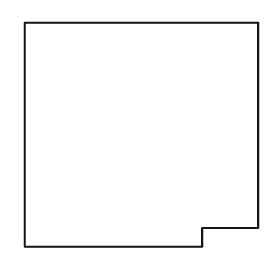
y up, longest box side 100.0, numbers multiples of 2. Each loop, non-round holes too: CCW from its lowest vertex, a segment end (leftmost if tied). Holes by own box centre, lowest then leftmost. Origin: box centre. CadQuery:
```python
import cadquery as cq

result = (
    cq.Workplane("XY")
    .moveTo(-50.0, -48.0)
    .lineTo(26.0, -48.0)
    .lineTo(26.0, -40.0)
    .lineTo(50.0, -40.0)
    .lineTo(50.0, 48.0)
    .lineTo(-50.0, 48.0)
    .close()
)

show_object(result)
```